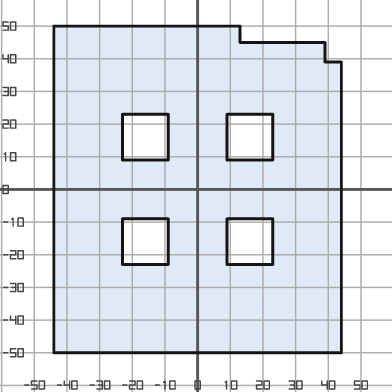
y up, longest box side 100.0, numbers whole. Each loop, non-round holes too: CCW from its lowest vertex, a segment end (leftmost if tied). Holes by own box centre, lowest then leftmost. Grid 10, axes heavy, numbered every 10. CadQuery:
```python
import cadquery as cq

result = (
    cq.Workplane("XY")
    .moveTo(-44.0, -50.0)
    .lineTo(44.0, -50.0)
    .lineTo(44.0, 39.0)
    .lineTo(39.0, 39.0)
    .lineTo(39.0, 45.0)
    .lineTo(13.0, 45.0)
    .lineTo(13.0, 50.0)
    .lineTo(-44.0, 50.0)
    .close()
    .moveTo(-23.0, -23.0)
    .lineTo(-9.0, -23.0)
    .lineTo(-9.0, -9.0)
    .lineTo(-23.0, -9.0)
    .close()
    .moveTo(9.0, -23.0)
    .lineTo(23.0, -23.0)
    .lineTo(23.0, -9.0)
    .lineTo(9.0, -9.0)
    .close()
    .moveTo(-23.0, 9.0)
    .lineTo(-9.0, 9.0)
    .lineTo(-9.0, 23.0)
    .lineTo(-23.0, 23.0)
    .close()
    .moveTo(9.0, 9.0)
    .lineTo(23.0, 9.0)
    .lineTo(23.0, 23.0)
    .lineTo(9.0, 23.0)
    .close()
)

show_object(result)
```